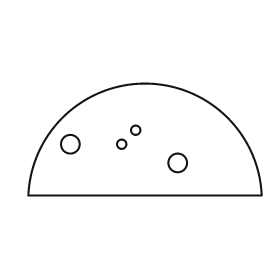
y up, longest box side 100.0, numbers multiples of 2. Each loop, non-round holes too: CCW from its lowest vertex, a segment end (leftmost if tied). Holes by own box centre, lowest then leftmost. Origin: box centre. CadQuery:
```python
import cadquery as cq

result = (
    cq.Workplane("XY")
    .moveTo(-50.0, -24.0)
    .lineTo(50.0, -24.0)
    .threePointArc((0.0, 24.0), (-50.0, -24.0))
    .close()
    .moveTo(14.0, -10.0)
    .circle(4.0)
    .moveTo(-32.0, -2.0)
    .circle(4.0)
    .moveTo(-10.0, -2.0)
    .circle(2.0)
    .moveTo(-4.0, 4.0)
    .circle(2.0)
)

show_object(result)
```